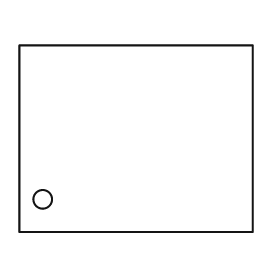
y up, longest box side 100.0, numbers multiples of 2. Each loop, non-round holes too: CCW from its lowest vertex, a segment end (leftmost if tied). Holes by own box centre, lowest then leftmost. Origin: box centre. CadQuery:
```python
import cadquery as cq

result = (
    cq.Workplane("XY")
    .moveTo(-50.0, -40.0)
    .lineTo(50.0, -40.0)
    .lineTo(50.0, 40.0)
    .lineTo(-50.0, 40.0)
    .close()
    .moveTo(-40.0, -26.0)
    .circle(4.0)
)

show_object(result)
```